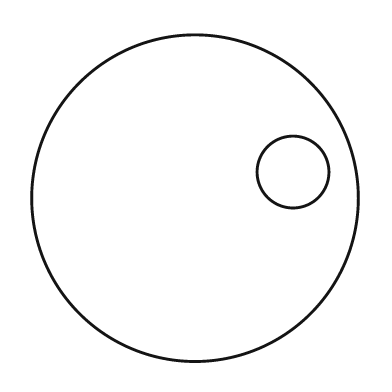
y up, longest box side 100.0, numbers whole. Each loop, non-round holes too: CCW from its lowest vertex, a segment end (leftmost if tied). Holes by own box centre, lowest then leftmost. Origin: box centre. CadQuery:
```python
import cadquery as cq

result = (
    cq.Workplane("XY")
    .moveTo(0.0, 0.0)
    .circle(50.0)
    .moveTo(30.0, 8.0)
    .circle(11.0)
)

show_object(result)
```